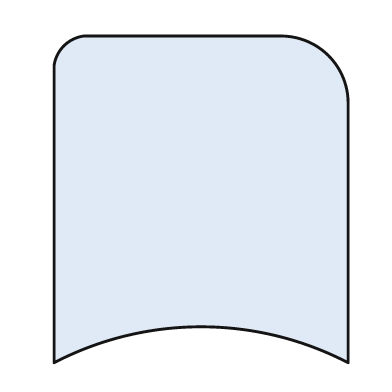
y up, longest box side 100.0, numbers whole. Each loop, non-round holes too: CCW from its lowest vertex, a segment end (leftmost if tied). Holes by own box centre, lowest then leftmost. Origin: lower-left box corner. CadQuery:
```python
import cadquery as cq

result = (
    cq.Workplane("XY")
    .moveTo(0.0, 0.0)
    .threePointArc((45.0, 11.0), (90.0, 0.0))
    .lineTo(90.0, 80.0)
    .threePointArc((84.0, 94.0), (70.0, 100.0))
    .lineTo(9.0, 100.0)
    .threePointArc((3.0, 97.0), (0.0, 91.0))
    .close()
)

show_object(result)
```